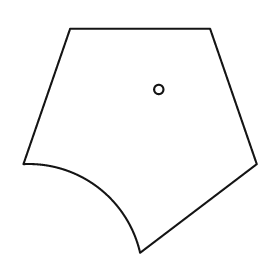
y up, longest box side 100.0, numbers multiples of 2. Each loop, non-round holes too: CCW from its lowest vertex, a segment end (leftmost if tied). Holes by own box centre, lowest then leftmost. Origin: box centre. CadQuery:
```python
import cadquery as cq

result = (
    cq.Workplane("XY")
    .moveTo(0.0, -48.0)
    .lineTo(50.0, -10.0)
    .lineTo(30.0, 48.0)
    .lineTo(-30.0, 48.0)
    .lineTo(-50.0, -10.0)
    .threePointArc((-18.0, -20.0), (0.0, -48.0))
    .close()
    .moveTo(8.0, 22.0)
    .circle(2.0)
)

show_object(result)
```